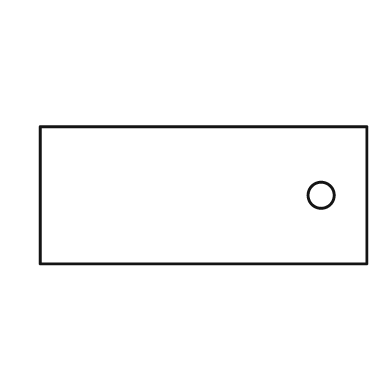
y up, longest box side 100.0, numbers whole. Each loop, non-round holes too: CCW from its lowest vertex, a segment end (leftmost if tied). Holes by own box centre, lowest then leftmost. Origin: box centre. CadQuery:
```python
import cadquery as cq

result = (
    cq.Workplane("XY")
    .moveTo(-50.0, -21.0)
    .lineTo(50.0, -21.0)
    .lineTo(50.0, 21.0)
    .lineTo(-50.0, 21.0)
    .close()
    .moveTo(36.0, 0.0)
    .circle(4.0)
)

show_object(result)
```